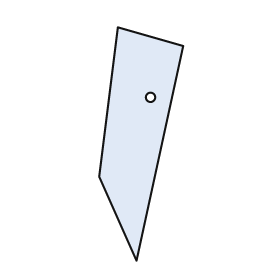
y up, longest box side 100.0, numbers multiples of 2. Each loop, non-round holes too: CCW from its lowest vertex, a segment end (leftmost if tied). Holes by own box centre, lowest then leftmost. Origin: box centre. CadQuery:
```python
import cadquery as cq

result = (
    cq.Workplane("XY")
    .moveTo(-2.0, -50.0)
    .lineTo(18.0, 42.0)
    .lineTo(-10.0, 50.0)
    .lineTo(-18.0, -14.0)
    .close()
    .moveTo(4.0, 20.0)
    .circle(2.0)
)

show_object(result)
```